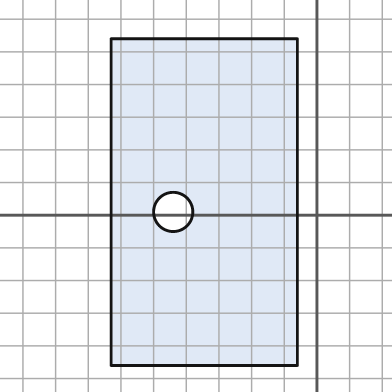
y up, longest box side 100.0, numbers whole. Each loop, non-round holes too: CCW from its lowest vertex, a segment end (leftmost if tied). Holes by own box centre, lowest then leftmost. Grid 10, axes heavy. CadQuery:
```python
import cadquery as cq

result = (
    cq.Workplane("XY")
    .moveTo(-63.0, -46.0)
    .lineTo(-6.0, -46.0)
    .lineTo(-6.0, 54.0)
    .lineTo(-63.0, 54.0)
    .close()
    .moveTo(-44.0, 1.0)
    .circle(6.0)
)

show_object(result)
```